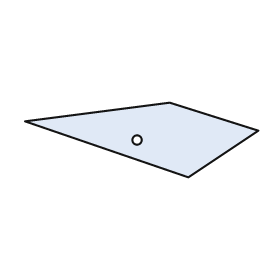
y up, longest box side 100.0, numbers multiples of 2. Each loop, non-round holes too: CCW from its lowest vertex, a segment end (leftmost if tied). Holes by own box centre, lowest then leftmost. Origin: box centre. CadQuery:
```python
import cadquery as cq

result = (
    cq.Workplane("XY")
    .moveTo(20.0, -16.0)
    .lineTo(50.0, 4.0)
    .lineTo(12.0, 16.0)
    .lineTo(-50.0, 8.0)
    .close()
    .moveTo(-2.0, 0.0)
    .circle(2.0)
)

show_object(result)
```